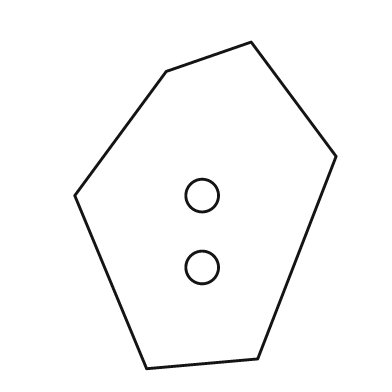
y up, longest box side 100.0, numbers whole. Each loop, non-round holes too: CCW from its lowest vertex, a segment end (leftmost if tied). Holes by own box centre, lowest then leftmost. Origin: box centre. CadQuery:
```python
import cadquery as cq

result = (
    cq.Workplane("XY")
    .moveTo(-18.0, -50.0)
    .lineTo(16.0, -47.0)
    .lineTo(40.0, 15.0)
    .lineTo(14.0, 50.0)
    .lineTo(-12.0, 41.0)
    .lineTo(-40.0, 3.0)
    .close()
    .moveTo(-1.0, -19.0)
    .circle(5.0)
    .moveTo(-1.0, 3.0)
    .circle(5.0)
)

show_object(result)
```